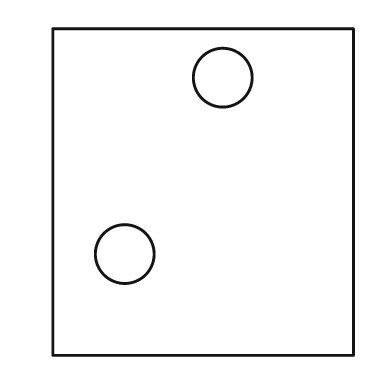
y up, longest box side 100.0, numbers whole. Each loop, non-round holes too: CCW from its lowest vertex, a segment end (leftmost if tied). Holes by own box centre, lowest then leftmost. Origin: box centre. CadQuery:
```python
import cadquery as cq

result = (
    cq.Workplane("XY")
    .moveTo(-46.0, -50.0)
    .lineTo(46.0, -50.0)
    .lineTo(46.0, 50.0)
    .lineTo(-46.0, 50.0)
    .close()
    .moveTo(-24.0, -19.0)
    .circle(9.0)
    .moveTo(6.0, 35.0)
    .circle(9.0)
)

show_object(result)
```